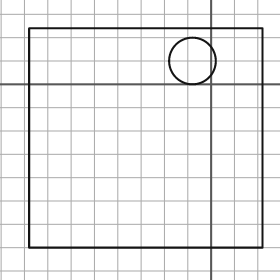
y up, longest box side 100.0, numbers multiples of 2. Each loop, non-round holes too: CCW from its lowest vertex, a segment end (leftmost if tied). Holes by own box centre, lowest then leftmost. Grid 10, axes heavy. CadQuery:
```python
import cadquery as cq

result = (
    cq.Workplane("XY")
    .moveTo(-78.0, -70.0)
    .lineTo(22.0, -70.0)
    .lineTo(22.0, 24.0)
    .lineTo(-78.0, 24.0)
    .close()
    .moveTo(-8.0, 10.0)
    .circle(10.0)
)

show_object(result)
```